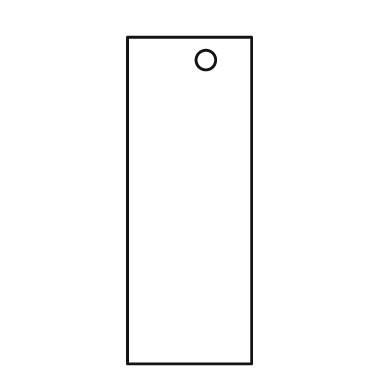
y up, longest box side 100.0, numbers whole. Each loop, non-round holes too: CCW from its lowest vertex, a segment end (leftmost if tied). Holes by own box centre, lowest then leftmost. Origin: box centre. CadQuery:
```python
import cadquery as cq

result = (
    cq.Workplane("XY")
    .moveTo(-19.0, -50.0)
    .lineTo(19.0, -50.0)
    .lineTo(19.0, 50.0)
    .lineTo(-19.0, 50.0)
    .close()
    .moveTo(5.0, 43.0)
    .circle(3.0)
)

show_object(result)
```